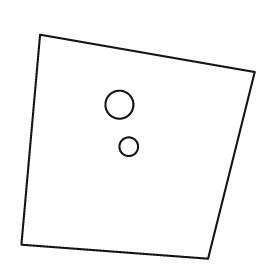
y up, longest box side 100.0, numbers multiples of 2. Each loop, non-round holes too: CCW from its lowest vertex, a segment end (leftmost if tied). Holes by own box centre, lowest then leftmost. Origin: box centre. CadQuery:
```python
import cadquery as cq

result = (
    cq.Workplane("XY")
    .moveTo(30.0, -48.0)
    .lineTo(50.0, 32.0)
    .lineTo(-42.0, 48.0)
    .lineTo(-50.0, -42.0)
    .close()
    .moveTo(-4.0, 0.0)
    .circle(4.0)
    .moveTo(-8.0, 18.0)
    .circle(6.0)
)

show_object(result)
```